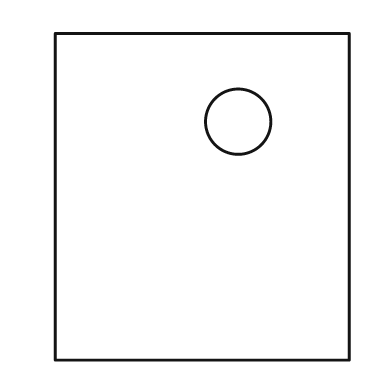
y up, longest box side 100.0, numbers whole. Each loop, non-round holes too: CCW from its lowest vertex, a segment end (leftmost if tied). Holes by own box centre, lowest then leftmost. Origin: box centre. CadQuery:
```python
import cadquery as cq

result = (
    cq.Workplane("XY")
    .moveTo(-45.0, -50.0)
    .lineTo(45.0, -50.0)
    .lineTo(45.0, 50.0)
    .lineTo(-45.0, 50.0)
    .close()
    .moveTo(11.0, 23.0)
    .circle(10.0)
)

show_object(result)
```